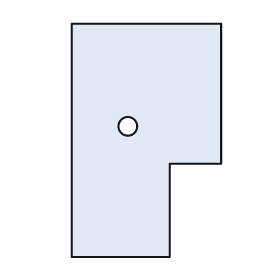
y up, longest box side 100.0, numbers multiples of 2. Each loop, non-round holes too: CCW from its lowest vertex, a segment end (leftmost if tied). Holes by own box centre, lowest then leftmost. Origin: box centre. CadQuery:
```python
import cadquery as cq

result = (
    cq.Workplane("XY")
    .moveTo(-32.0, -50.0)
    .lineTo(10.0, -50.0)
    .lineTo(10.0, -10.0)
    .lineTo(32.0, -10.0)
    .lineTo(32.0, 50.0)
    .lineTo(-32.0, 50.0)
    .close()
    .moveTo(-8.0, 6.0)
    .circle(4.0)
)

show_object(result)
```